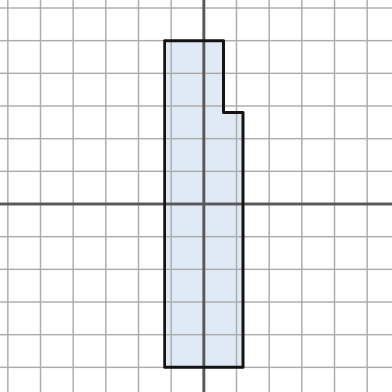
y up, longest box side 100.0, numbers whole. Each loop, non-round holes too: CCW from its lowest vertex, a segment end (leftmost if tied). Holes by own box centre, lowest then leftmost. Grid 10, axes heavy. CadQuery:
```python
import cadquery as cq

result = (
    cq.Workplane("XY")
    .moveTo(-12.0, -50.0)
    .lineTo(12.0, -50.0)
    .lineTo(12.0, 28.0)
    .lineTo(6.0, 28.0)
    .lineTo(6.0, 50.0)
    .lineTo(-12.0, 50.0)
    .close()
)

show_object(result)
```